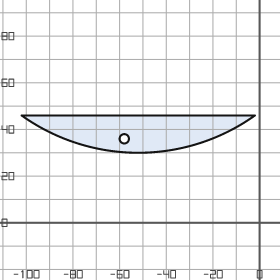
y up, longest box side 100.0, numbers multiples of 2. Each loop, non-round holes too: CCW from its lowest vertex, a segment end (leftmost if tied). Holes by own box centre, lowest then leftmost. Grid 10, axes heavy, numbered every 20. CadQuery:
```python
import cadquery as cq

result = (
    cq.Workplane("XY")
    .moveTo(-102.0, 46.0)
    .threePointArc((-52.0, 30.0), (-2.0, 46.0))
    .close()
    .moveTo(-58.0, 36.0)
    .circle(2.0)
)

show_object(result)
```